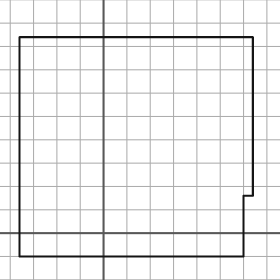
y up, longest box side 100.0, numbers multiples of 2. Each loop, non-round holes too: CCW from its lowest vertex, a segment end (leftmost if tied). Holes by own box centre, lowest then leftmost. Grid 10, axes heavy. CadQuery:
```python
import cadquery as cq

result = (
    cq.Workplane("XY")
    .moveTo(-36.0, -10.0)
    .lineTo(60.0, -10.0)
    .lineTo(60.0, 16.0)
    .lineTo(64.0, 16.0)
    .lineTo(64.0, 84.0)
    .lineTo(-36.0, 84.0)
    .close()
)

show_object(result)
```